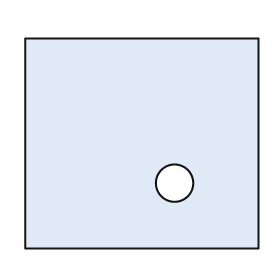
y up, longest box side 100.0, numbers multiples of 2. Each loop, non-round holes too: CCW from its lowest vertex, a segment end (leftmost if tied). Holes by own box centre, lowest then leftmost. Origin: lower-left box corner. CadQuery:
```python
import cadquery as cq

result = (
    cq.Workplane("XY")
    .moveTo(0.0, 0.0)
    .lineTo(100.0, 0.0)
    .lineTo(100.0, 90.0)
    .lineTo(0.0, 90.0)
    .close()
    .moveTo(64.0, 28.0)
    .circle(8.0)
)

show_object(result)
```